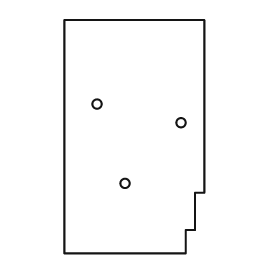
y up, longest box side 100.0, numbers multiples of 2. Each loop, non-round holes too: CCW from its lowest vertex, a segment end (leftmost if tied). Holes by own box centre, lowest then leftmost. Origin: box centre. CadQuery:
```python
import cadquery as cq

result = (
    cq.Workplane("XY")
    .moveTo(-30.0, -50.0)
    .lineTo(22.0, -50.0)
    .lineTo(22.0, -40.0)
    .lineTo(26.0, -40.0)
    .lineTo(26.0, -24.0)
    .lineTo(30.0, -24.0)
    .lineTo(30.0, 50.0)
    .lineTo(-30.0, 50.0)
    .close()
    .moveTo(-4.0, -20.0)
    .circle(2.0)
    .moveTo(20.0, 6.0)
    .circle(2.0)
    .moveTo(-16.0, 14.0)
    .circle(2.0)
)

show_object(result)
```